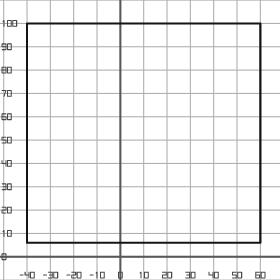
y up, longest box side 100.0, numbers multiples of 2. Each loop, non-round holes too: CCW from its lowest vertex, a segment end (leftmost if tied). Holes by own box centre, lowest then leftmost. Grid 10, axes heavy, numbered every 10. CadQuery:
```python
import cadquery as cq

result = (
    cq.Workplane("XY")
    .moveTo(-40.0, 6.0)
    .lineTo(60.0, 6.0)
    .lineTo(60.0, 100.0)
    .lineTo(-40.0, 100.0)
    .close()
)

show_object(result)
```